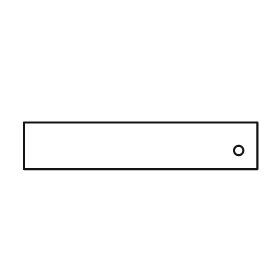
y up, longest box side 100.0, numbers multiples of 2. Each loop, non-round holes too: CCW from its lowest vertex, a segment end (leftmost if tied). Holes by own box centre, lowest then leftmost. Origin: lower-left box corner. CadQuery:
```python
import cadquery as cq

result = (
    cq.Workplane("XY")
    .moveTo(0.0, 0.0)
    .lineTo(100.0, 0.0)
    .lineTo(100.0, 20.0)
    .lineTo(0.0, 20.0)
    .close()
    .moveTo(92.0, 8.0)
    .circle(2.0)
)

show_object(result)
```